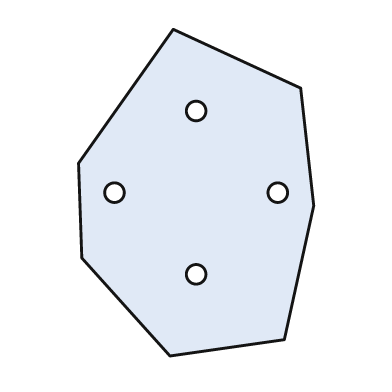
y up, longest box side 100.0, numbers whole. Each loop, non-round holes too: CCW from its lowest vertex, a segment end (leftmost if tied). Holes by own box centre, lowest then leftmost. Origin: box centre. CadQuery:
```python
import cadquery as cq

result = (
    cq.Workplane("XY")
    .moveTo(-8.0, -50.0)
    .lineTo(27.0, -45.0)
    .lineTo(36.0, -4.0)
    .lineTo(32.0, 32.0)
    .lineTo(-7.0, 50.0)
    .lineTo(-36.0, 9.0)
    .lineTo(-35.0, -20.0)
    .close()
    .moveTo(0.0, -25.0)
    .circle(3.0)
    .moveTo(-25.0, 0.0)
    .circle(3.0)
    .moveTo(25.0, 0.0)
    .circle(3.0)
    .moveTo(0.0, 25.0)
    .circle(3.0)
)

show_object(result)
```